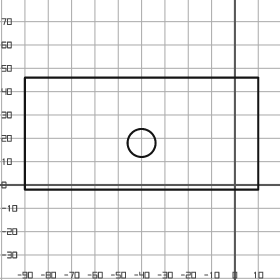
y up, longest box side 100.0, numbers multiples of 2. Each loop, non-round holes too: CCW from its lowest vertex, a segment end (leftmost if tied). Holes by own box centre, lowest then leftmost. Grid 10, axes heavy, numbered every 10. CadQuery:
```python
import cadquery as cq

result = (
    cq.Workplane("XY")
    .moveTo(-90.0, -2.0)
    .lineTo(10.0, -2.0)
    .lineTo(10.0, 46.0)
    .lineTo(-90.0, 46.0)
    .close()
    .moveTo(-40.0, 18.0)
    .circle(6.0)
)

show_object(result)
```